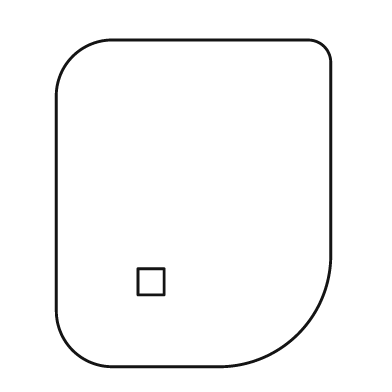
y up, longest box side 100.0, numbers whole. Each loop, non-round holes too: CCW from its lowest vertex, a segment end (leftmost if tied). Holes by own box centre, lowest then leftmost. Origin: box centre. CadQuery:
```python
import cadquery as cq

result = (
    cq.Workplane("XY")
    .moveTo(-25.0, -50.0)
    .lineTo(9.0, -50.0)
    .threePointArc((32.0, -40.0), (42.0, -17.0))
    .lineTo(42.0, 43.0)
    .threePointArc((40.0, 48.0), (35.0, 50.0))
    .lineTo(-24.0, 50.0)
    .threePointArc((-37.0, 45.0), (-42.0, 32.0))
    .lineTo(-42.0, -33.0)
    .threePointArc((-37.0, -45.0), (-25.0, -50.0))
    .close()
    .moveTo(-17.0, -28.0)
    .lineTo(-9.0, -28.0)
    .lineTo(-9.0, -20.0)
    .lineTo(-17.0, -20.0)
    .close()
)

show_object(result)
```